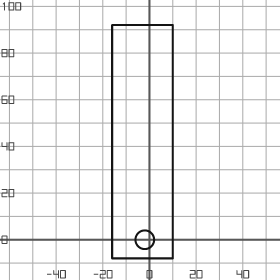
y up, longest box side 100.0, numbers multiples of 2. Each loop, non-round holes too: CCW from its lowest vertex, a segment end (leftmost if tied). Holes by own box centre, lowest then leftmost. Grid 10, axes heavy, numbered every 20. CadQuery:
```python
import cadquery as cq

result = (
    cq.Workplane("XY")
    .moveTo(-16.0, -8.0)
    .lineTo(10.0, -8.0)
    .lineTo(10.0, 92.0)
    .lineTo(-16.0, 92.0)
    .close()
    .moveTo(-2.0, 0.0)
    .circle(4.0)
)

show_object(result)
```